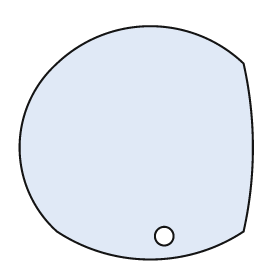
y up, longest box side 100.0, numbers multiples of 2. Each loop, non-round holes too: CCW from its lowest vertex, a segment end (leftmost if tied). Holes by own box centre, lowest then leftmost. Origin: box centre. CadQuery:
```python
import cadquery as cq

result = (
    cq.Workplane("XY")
    .moveTo(-34.0, -38.0)
    .threePointArc((6.0, -50.0), (46.0, -38.0))
    .threePointArc((50.0, -2.0), (46.0, 34.0))
    .threePointArc((6.0, 50.0), (-34.0, 34.0))
    .threePointArc((-50.0, -2.0), (-34.0, -38.0))
    .close()
    .moveTo(12.0, -40.0)
    .circle(4.0)
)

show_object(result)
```